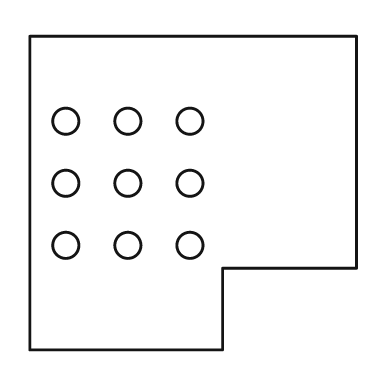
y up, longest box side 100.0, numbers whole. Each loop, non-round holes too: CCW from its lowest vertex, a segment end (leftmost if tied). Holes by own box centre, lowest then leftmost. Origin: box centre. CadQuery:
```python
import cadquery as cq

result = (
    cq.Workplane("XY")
    .moveTo(-50.0, -48.0)
    .lineTo(9.0, -48.0)
    .lineTo(9.0, -23.0)
    .lineTo(50.0, -23.0)
    .lineTo(50.0, 48.0)
    .lineTo(-50.0, 48.0)
    .close()
    .moveTo(-39.0, -16.0)
    .circle(4.0)
    .moveTo(-20.0, -16.0)
    .circle(4.0)
    .moveTo(-1.0, -16.0)
    .circle(4.0)
    .moveTo(-39.0, 3.0)
    .circle(4.0)
    .moveTo(-20.0, 3.0)
    .circle(4.0)
    .moveTo(-1.0, 3.0)
    .circle(4.0)
    .moveTo(-39.0, 22.0)
    .circle(4.0)
    .moveTo(-20.0, 22.0)
    .circle(4.0)
    .moveTo(-1.0, 22.0)
    .circle(4.0)
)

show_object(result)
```